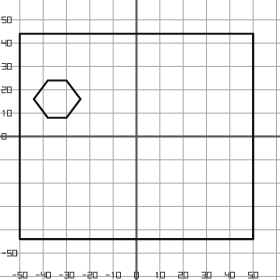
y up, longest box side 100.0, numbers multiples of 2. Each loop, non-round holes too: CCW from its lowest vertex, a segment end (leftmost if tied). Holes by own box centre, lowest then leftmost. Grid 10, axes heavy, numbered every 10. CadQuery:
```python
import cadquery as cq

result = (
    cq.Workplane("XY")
    .moveTo(-50.0, -44.0)
    .lineTo(50.0, -44.0)
    .lineTo(50.0, 44.0)
    .lineTo(-50.0, 44.0)
    .close()
    .moveTo(-38.0, 8.0)
    .lineTo(-30.0, 8.0)
    .lineTo(-24.0, 16.0)
    .lineTo(-30.0, 24.0)
    .lineTo(-38.0, 24.0)
    .lineTo(-44.0, 16.0)
    .close()
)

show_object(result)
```